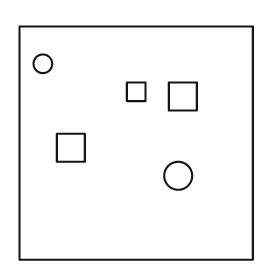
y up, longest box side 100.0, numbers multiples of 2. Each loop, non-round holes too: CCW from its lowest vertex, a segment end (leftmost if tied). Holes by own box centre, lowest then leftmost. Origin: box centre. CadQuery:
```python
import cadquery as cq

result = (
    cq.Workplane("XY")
    .moveTo(-50.0, -50.0)
    .lineTo(50.0, -50.0)
    .lineTo(50.0, 50.0)
    .lineTo(-50.0, 50.0)
    .close()
    .moveTo(18.0, -14.0)
    .circle(6.0)
    .moveTo(-34.0, -8.0)
    .lineTo(-22.0, -8.0)
    .lineTo(-22.0, 4.0)
    .lineTo(-34.0, 4.0)
    .close()
    .moveTo(14.0, 14.0)
    .lineTo(26.0, 14.0)
    .lineTo(26.0, 26.0)
    .lineTo(14.0, 26.0)
    .close()
    .moveTo(-4.0, 18.0)
    .lineTo(4.0, 18.0)
    .lineTo(4.0, 26.0)
    .lineTo(-4.0, 26.0)
    .close()
    .moveTo(-40.0, 34.0)
    .circle(4.0)
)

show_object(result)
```